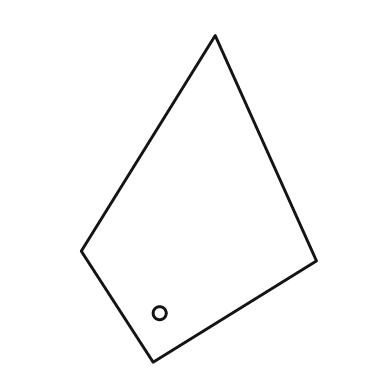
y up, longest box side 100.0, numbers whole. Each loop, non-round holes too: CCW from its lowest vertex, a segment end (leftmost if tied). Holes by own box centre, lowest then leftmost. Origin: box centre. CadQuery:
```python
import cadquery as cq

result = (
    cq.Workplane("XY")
    .moveTo(-14.0, -50.0)
    .lineTo(36.0, -19.0)
    .lineTo(5.0, 50.0)
    .lineTo(-36.0, -16.0)
    .close()
    .moveTo(-12.0, -35.0)
    .circle(2.0)
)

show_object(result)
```